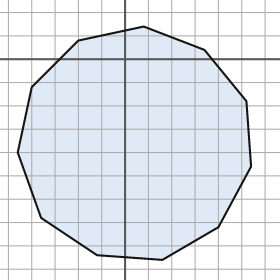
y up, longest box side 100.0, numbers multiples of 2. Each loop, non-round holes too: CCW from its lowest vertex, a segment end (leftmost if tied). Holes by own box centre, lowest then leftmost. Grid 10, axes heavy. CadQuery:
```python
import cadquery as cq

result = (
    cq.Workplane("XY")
    .moveTo(16.0, -86.0)
    .lineTo(40.0, -72.0)
    .lineTo(54.0, -46.0)
    .lineTo(52.0, -18.0)
    .lineTo(34.0, 4.0)
    .lineTo(8.0, 14.0)
    .lineTo(-20.0, 8.0)
    .lineTo(-40.0, -12.0)
    .lineTo(-46.0, -40.0)
    .lineTo(-36.0, -68.0)
    .lineTo(-12.0, -84.0)
    .close()
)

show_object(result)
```